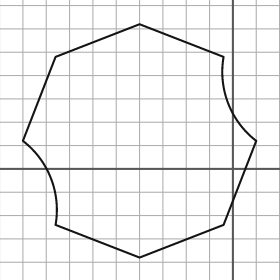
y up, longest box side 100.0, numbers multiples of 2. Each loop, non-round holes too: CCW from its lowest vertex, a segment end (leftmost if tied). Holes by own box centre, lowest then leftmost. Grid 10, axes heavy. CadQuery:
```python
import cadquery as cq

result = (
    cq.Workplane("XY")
    .moveTo(-40.0, -38.0)
    .lineTo(-4.0, -24.0)
    .lineTo(10.0, 12.0)
    .threePointArc((-2.0, 28.0), (-4.0, 48.0))
    .lineTo(-40.0, 62.0)
    .lineTo(-76.0, 48.0)
    .lineTo(-90.0, 12.0)
    .threePointArc((-78.0, -4.0), (-76.0, -24.0))
    .close()
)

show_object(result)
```